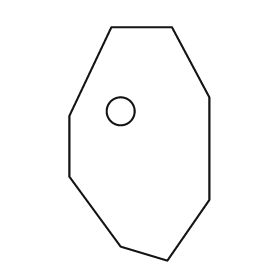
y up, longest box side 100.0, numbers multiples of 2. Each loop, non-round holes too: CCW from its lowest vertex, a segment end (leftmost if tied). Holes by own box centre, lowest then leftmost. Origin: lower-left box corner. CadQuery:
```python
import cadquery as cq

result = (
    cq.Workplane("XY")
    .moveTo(42.0, 0.0)
    .lineTo(60.0, 26.0)
    .lineTo(60.0, 70.0)
    .lineTo(44.0, 100.0)
    .lineTo(18.0, 100.0)
    .lineTo(0.0, 62.0)
    .lineTo(0.0, 36.0)
    .lineTo(22.0, 6.0)
    .close()
    .moveTo(22.0, 64.0)
    .circle(6.0)
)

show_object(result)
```